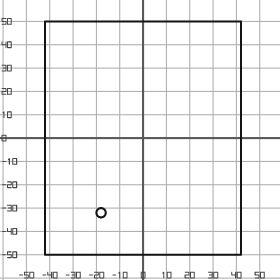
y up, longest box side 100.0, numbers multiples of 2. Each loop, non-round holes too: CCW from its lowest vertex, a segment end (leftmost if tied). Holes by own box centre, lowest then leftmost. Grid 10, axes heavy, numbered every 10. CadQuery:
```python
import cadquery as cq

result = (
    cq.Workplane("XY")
    .moveTo(-42.0, -50.0)
    .lineTo(42.0, -50.0)
    .lineTo(42.0, 50.0)
    .lineTo(-42.0, 50.0)
    .close()
    .moveTo(-18.0, -32.0)
    .circle(2.0)
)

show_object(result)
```